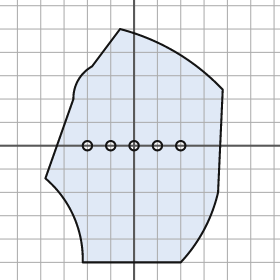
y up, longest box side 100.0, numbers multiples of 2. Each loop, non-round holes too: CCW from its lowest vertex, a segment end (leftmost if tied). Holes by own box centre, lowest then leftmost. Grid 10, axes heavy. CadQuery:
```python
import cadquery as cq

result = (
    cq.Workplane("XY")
    .moveTo(-22.0, -50.0)
    .lineTo(20.0, -50.0)
    .threePointArc((30.0, -36.0), (36.0, -20.0))
    .lineTo(38.0, 24.0)
    .threePointArc((18.0, 40.0), (-6.0, 50.0))
    .lineTo(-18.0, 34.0)
    .threePointArc((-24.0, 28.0), (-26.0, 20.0))
    .lineTo(-38.0, -14.0)
    .threePointArc((-26.0, -30.0), (-22.0, -50.0))
    .close()
    .moveTo(-20.0, 0.0)
    .circle(2.0)
    .moveTo(-10.0, 0.0)
    .circle(2.0)
    .moveTo(0.0, 0.0)
    .circle(2.0)
    .moveTo(10.0, 0.0)
    .circle(2.0)
    .moveTo(20.0, 0.0)
    .circle(2.0)
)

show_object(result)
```